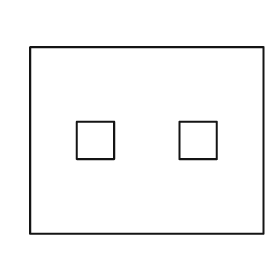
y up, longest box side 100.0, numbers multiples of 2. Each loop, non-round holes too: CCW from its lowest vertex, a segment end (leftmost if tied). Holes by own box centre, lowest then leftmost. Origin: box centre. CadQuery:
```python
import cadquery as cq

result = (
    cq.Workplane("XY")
    .moveTo(-50.0, -40.0)
    .lineTo(50.0, -40.0)
    .lineTo(50.0, 40.0)
    .lineTo(-50.0, 40.0)
    .close()
    .moveTo(-30.0, -8.0)
    .lineTo(-14.0, -8.0)
    .lineTo(-14.0, 8.0)
    .lineTo(-30.0, 8.0)
    .close()
    .moveTo(14.0, -8.0)
    .lineTo(30.0, -8.0)
    .lineTo(30.0, 8.0)
    .lineTo(14.0, 8.0)
    .close()
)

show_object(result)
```